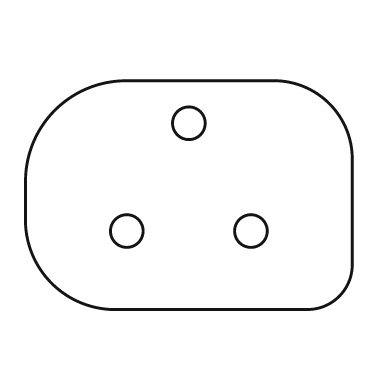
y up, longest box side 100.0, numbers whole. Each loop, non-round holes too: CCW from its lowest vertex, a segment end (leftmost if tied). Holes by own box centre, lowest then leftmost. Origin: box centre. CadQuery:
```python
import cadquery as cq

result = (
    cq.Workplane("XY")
    .moveTo(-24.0, -35.0)
    .lineTo(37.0, -35.0)
    .threePointArc((46.0, -31.0), (50.0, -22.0))
    .lineTo(50.0, 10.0)
    .threePointArc((43.0, 28.0), (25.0, 35.0))
    .lineTo(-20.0, 35.0)
    .threePointArc((-41.0, 26.0), (-50.0, 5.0))
    .lineTo(-50.0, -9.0)
    .threePointArc((-42.0, -27.0), (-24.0, -35.0))
    .close()
    .moveTo(-19.0, -11.0)
    .circle(5.0)
    .moveTo(19.0, -11.0)
    .circle(5.0)
    .moveTo(0.0, 22.0)
    .circle(5.0)
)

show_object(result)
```